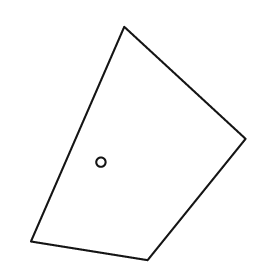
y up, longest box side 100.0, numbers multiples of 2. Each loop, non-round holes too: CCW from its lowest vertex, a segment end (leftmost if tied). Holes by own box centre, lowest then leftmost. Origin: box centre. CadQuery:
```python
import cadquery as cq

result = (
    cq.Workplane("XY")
    .moveTo(4.0, -50.0)
    .lineTo(46.0, 2.0)
    .lineTo(-6.0, 50.0)
    .lineTo(-46.0, -42.0)
    .close()
    .moveTo(-16.0, -8.0)
    .circle(2.0)
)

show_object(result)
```